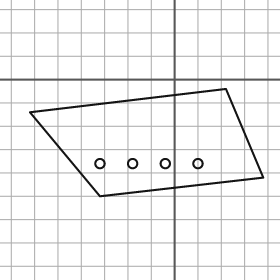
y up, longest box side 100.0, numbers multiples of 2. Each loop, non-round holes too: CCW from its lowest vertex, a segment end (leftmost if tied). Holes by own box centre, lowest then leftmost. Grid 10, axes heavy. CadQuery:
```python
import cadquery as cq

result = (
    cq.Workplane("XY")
    .moveTo(-32.0, -50.0)
    .lineTo(38.0, -42.0)
    .lineTo(22.0, -4.0)
    .lineTo(-62.0, -14.0)
    .close()
    .moveTo(-32.0, -36.0)
    .circle(2.0)
    .moveTo(-18.0, -36.0)
    .circle(2.0)
    .moveTo(-4.0, -36.0)
    .circle(2.0)
    .moveTo(10.0, -36.0)
    .circle(2.0)
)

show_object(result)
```